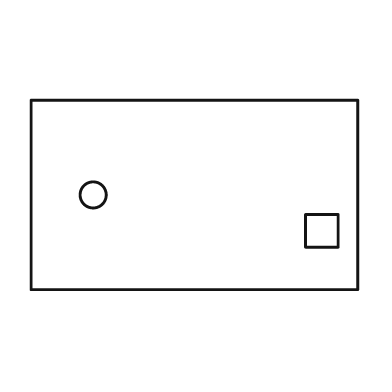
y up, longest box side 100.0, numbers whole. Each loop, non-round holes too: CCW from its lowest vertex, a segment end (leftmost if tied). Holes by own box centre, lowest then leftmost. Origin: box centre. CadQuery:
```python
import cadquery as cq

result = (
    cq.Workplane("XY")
    .moveTo(-50.0, -29.0)
    .lineTo(50.0, -29.0)
    .lineTo(50.0, 29.0)
    .lineTo(-50.0, 29.0)
    .close()
    .moveTo(34.0, -16.0)
    .lineTo(44.0, -16.0)
    .lineTo(44.0, -6.0)
    .lineTo(34.0, -6.0)
    .close()
    .moveTo(-31.0, 0.0)
    .circle(4.0)
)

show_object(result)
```